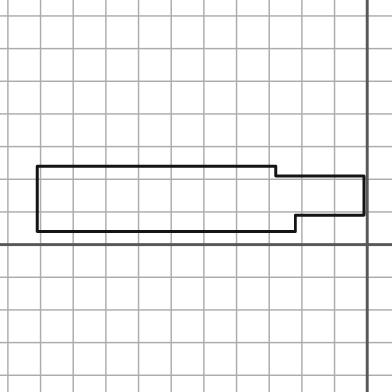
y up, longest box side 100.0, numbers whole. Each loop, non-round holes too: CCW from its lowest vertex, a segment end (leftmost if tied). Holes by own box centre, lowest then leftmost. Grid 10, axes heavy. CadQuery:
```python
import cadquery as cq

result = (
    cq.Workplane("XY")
    .moveTo(-101.0, 4.0)
    .lineTo(-22.0, 4.0)
    .lineTo(-22.0, 9.0)
    .lineTo(-1.0, 9.0)
    .lineTo(-1.0, 21.0)
    .lineTo(-28.0, 21.0)
    .lineTo(-28.0, 24.0)
    .lineTo(-101.0, 24.0)
    .close()
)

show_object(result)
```